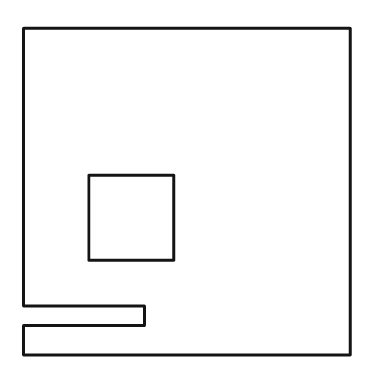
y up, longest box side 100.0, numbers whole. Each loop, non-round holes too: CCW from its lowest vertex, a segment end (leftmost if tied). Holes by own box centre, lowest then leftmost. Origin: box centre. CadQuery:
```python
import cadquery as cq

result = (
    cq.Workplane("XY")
    .moveTo(-50.0, -50.0)
    .lineTo(50.0, -50.0)
    .lineTo(50.0, 50.0)
    .lineTo(-50.0, 50.0)
    .lineTo(-50.0, -35.0)
    .lineTo(-13.0, -35.0)
    .lineTo(-13.0, -41.0)
    .lineTo(-50.0, -41.0)
    .close()
    .moveTo(-30.0, -21.0)
    .lineTo(-4.0, -21.0)
    .lineTo(-4.0, 5.0)
    .lineTo(-30.0, 5.0)
    .close()
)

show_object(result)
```